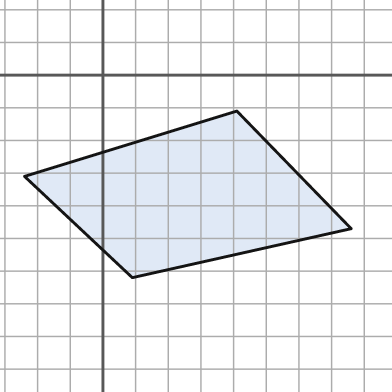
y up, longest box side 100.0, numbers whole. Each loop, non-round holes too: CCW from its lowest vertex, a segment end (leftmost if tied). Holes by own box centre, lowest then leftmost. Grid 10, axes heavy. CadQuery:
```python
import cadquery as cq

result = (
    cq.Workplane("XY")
    .moveTo(9.0, -62.0)
    .lineTo(76.0, -47.0)
    .lineTo(41.0, -11.0)
    .lineTo(-24.0, -31.0)
    .close()
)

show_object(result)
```